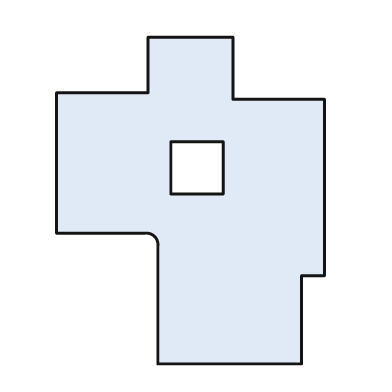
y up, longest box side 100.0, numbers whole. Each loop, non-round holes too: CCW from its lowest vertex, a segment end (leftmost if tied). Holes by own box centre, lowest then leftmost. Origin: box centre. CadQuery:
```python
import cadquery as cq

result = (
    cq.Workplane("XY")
    .moveTo(-10.0, -50.0)
    .lineTo(34.0, -50.0)
    .lineTo(34.0, -23.0)
    .lineTo(41.0, -23.0)
    .lineTo(41.0, 31.0)
    .lineTo(13.0, 31.0)
    .lineTo(13.0, 50.0)
    .lineTo(-13.0, 50.0)
    .lineTo(-13.0, 33.0)
    .lineTo(-41.0, 33.0)
    .lineTo(-41.0, -10.0)
    .lineTo(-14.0, -10.0)
    .threePointArc((-11.0, -11.0), (-10.0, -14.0))
    .close()
    .moveTo(-6.0, 2.0)
    .lineTo(10.0, 2.0)
    .lineTo(10.0, 18.0)
    .lineTo(-6.0, 18.0)
    .close()
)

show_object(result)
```